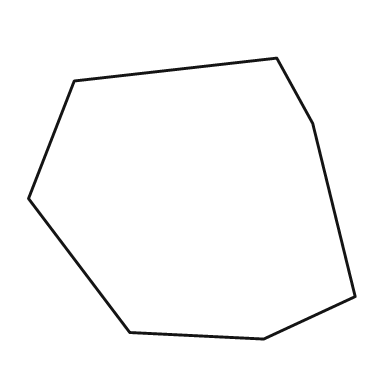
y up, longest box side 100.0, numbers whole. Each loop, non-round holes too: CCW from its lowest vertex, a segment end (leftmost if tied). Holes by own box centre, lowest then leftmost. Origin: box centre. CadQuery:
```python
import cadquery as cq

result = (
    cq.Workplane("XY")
    .moveTo(22.0, -43.0)
    .lineTo(50.0, -30.0)
    .lineTo(37.0, 23.0)
    .lineTo(26.0, 43.0)
    .lineTo(-36.0, 36.0)
    .lineTo(-50.0, 0.0)
    .lineTo(-19.0, -41.0)
    .close()
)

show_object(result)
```